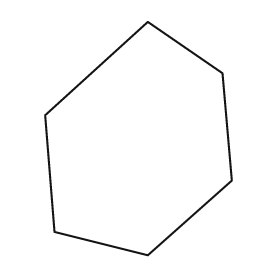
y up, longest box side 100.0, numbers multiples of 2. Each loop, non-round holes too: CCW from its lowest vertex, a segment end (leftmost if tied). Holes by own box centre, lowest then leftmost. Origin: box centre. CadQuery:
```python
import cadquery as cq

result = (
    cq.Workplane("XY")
    .moveTo(4.0, -50.0)
    .lineTo(40.0, -18.0)
    .lineTo(36.0, 28.0)
    .lineTo(4.0, 50.0)
    .lineTo(-40.0, 10.0)
    .lineTo(-36.0, -40.0)
    .close()
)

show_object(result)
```